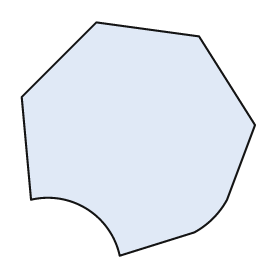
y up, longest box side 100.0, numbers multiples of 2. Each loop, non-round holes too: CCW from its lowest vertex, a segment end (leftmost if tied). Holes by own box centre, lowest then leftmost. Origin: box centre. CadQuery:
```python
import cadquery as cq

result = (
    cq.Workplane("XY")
    .moveTo(-8.0, -50.0)
    .lineTo(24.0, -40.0)
    .threePointArc((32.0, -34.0), (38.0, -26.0))
    .lineTo(50.0, 6.0)
    .lineTo(26.0, 44.0)
    .lineTo(-18.0, 50.0)
    .lineTo(-50.0, 18.0)
    .lineTo(-46.0, -26.0)
    .threePointArc((-22.0, -30.0), (-8.0, -50.0))
    .close()
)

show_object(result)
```